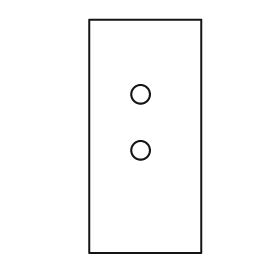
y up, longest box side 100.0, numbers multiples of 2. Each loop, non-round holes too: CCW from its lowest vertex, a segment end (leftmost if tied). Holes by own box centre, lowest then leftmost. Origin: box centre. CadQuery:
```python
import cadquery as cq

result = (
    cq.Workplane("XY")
    .moveTo(-24.0, -50.0)
    .lineTo(24.0, -50.0)
    .lineTo(24.0, 50.0)
    .lineTo(-24.0, 50.0)
    .close()
    .moveTo(-2.0, -6.0)
    .circle(4.0)
    .moveTo(-2.0, 18.0)
    .circle(4.0)
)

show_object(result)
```